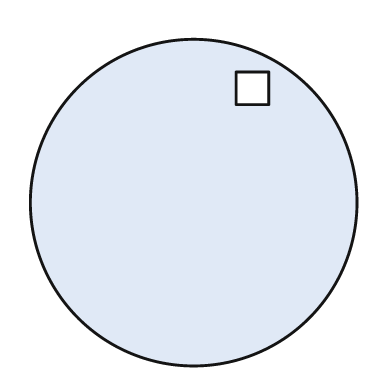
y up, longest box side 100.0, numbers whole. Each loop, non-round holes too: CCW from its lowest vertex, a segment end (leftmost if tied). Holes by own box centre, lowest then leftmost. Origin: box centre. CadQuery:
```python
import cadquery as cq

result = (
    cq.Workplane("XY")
    .moveTo(0.0, 0.0)
    .circle(50.0)
    .moveTo(13.0, 30.0)
    .lineTo(23.0, 30.0)
    .lineTo(23.0, 40.0)
    .lineTo(13.0, 40.0)
    .close()
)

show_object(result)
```